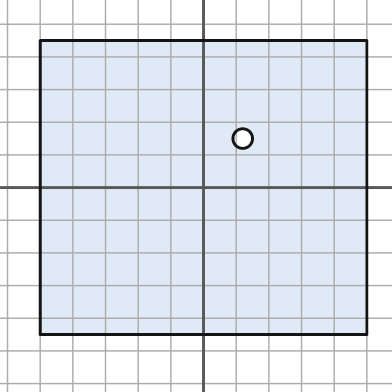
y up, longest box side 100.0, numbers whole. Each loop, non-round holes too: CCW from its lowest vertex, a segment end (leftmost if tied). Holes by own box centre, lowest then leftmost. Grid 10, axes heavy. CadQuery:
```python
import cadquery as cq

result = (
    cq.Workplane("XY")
    .moveTo(-50.0, -45.0)
    .lineTo(50.0, -45.0)
    .lineTo(50.0, 45.0)
    .lineTo(-50.0, 45.0)
    .close()
    .moveTo(12.0, 15.0)
    .circle(3.0)
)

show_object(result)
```